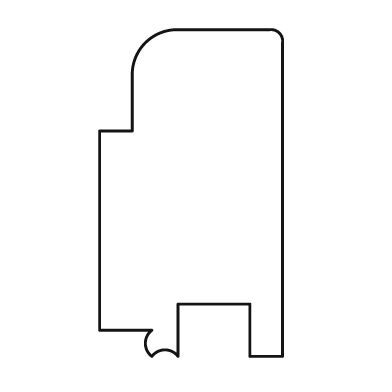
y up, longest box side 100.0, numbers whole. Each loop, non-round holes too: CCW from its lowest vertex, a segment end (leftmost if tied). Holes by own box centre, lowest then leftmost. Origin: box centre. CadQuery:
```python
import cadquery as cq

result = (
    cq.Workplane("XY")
    .moveTo(-12.0, -50.0)
    .threePointArc((-8.0, -48.0), (-4.0, -50.0))
    .lineTo(-4.0, -34.0)
    .lineTo(18.0, -34.0)
    .lineTo(18.0, -50.0)
    .lineTo(28.0, -50.0)
    .lineTo(28.0, 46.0)
    .threePointArc((27.0, 49.0), (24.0, 50.0))
    .lineTo(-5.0, 50.0)
    .threePointArc((-14.0, 46.0), (-18.0, 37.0))
    .lineTo(-18.0, 19.0)
    .lineTo(-28.0, 19.0)
    .lineTo(-28.0, -42.0)
    .lineTo(-12.0, -42.0)
    .threePointArc((-14.0, -46.0), (-12.0, -50.0))
    .close()
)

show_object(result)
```